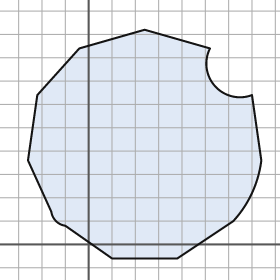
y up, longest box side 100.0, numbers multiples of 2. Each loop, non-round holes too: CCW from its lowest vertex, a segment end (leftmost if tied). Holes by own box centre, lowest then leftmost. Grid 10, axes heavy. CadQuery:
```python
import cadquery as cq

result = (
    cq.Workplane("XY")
    .moveTo(10.0, -6.0)
    .lineTo(38.0, -6.0)
    .lineTo(62.0, 10.0)
    .threePointArc((70.0, 22.0), (74.0, 36.0))
    .lineTo(70.0, 64.0)
    .threePointArc((54.0, 68.0), (52.0, 84.0))
    .lineTo(24.0, 92.0)
    .lineTo(-4.0, 84.0)
    .lineTo(-22.0, 64.0)
    .lineTo(-26.0, 36.0)
    .lineTo(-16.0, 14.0)
    .threePointArc((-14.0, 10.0), (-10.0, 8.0))
    .close()
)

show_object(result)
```